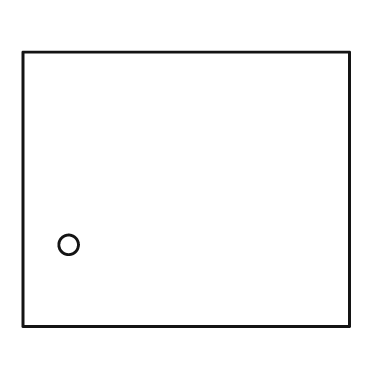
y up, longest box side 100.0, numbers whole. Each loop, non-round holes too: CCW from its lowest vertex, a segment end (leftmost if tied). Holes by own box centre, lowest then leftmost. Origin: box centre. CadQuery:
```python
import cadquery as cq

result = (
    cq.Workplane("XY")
    .moveTo(-50.0, -42.0)
    .lineTo(50.0, -42.0)
    .lineTo(50.0, 42.0)
    .lineTo(-50.0, 42.0)
    .close()
    .moveTo(-36.0, -17.0)
    .circle(3.0)
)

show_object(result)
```